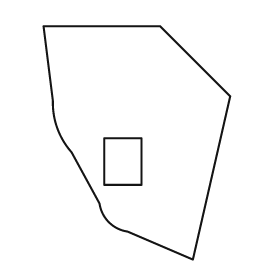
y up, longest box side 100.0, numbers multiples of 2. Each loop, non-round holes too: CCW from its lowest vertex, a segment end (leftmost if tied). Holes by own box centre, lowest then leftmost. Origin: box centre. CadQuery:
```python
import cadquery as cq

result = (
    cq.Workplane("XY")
    .moveTo(24.0, -50.0)
    .lineTo(40.0, 20.0)
    .lineTo(10.0, 50.0)
    .lineTo(-40.0, 50.0)
    .lineTo(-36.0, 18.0)
    .threePointArc((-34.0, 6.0), (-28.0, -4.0))
    .lineTo(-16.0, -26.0)
    .threePointArc((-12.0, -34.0), (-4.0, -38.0))
    .close()
    .moveTo(-14.0, -18.0)
    .lineTo(2.0, -18.0)
    .lineTo(2.0, 2.0)
    .lineTo(-14.0, 2.0)
    .close()
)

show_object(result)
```